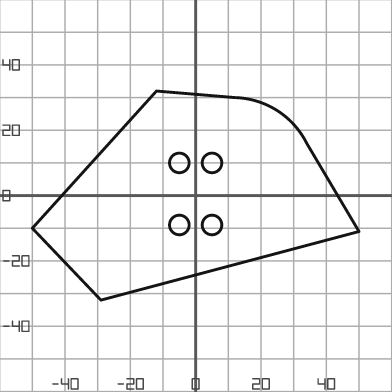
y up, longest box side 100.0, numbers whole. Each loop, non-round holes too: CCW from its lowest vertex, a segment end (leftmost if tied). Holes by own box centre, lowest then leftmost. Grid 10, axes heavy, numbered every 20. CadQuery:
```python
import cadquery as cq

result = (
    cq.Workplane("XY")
    .moveTo(-29.0, -32.0)
    .lineTo(50.0, -11.0)
    .lineTo(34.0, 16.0)
    .threePointArc((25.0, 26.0), (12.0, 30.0))
    .lineTo(-12.0, 32.0)
    .lineTo(-50.0, -10.0)
    .close()
    .moveTo(-5.0, -9.0)
    .circle(3.0)
    .moveTo(5.0, -9.0)
    .circle(3.0)
    .moveTo(-5.0, 10.0)
    .circle(3.0)
    .moveTo(5.0, 10.0)
    .circle(3.0)
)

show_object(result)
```